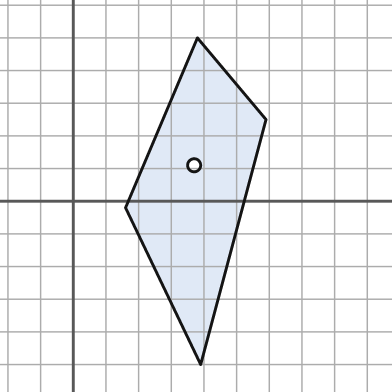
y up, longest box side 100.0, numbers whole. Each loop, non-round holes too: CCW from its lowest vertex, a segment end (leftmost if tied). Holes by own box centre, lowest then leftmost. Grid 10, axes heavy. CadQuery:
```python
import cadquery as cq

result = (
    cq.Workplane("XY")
    .moveTo(39.0, -50.0)
    .lineTo(59.0, 25.0)
    .lineTo(38.0, 50.0)
    .lineTo(16.0, -2.0)
    .close()
    .moveTo(37.0, 11.0)
    .circle(2.0)
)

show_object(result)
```